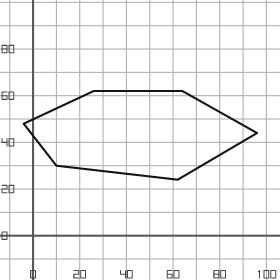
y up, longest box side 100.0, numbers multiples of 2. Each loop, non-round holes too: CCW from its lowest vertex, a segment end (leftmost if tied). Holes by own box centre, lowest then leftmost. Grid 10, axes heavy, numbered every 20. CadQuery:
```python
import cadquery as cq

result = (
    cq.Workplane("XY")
    .moveTo(62.0, 24.0)
    .lineTo(96.0, 44.0)
    .lineTo(64.0, 62.0)
    .lineTo(26.0, 62.0)
    .lineTo(-4.0, 48.0)
    .lineTo(10.0, 30.0)
    .close()
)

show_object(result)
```